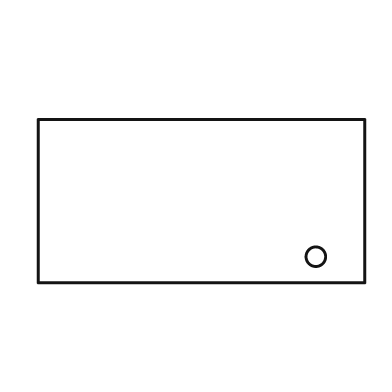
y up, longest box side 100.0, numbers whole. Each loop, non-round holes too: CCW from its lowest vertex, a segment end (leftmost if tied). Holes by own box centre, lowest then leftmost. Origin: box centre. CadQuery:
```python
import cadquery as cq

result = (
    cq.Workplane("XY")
    .moveTo(-50.0, -25.0)
    .lineTo(50.0, -25.0)
    .lineTo(50.0, 25.0)
    .lineTo(-50.0, 25.0)
    .close()
    .moveTo(35.0, -17.0)
    .circle(3.0)
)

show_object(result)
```